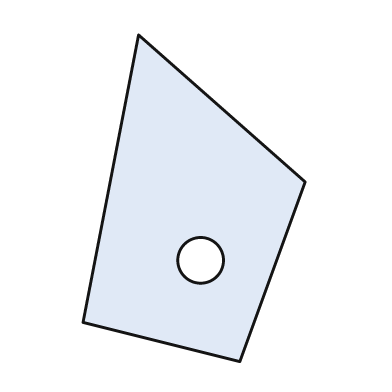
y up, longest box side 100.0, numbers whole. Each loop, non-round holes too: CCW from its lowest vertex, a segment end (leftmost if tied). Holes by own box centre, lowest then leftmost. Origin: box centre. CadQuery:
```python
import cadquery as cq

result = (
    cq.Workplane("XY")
    .moveTo(14.0, -50.0)
    .lineTo(34.0, 5.0)
    .lineTo(-17.0, 50.0)
    .lineTo(-34.0, -38.0)
    .close()
    .moveTo(2.0, -19.0)
    .circle(7.0)
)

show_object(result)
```